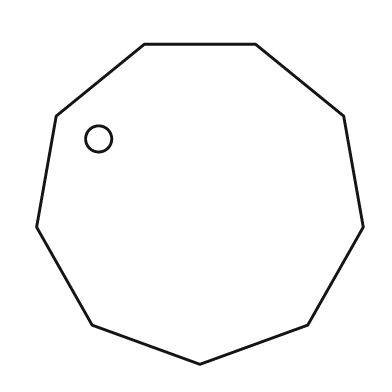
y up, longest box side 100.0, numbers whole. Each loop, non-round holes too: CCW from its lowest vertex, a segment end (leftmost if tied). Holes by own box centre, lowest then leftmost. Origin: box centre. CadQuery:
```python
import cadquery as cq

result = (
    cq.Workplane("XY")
    .moveTo(0.0, -49.0)
    .lineTo(33.0, -37.0)
    .lineTo(50.0, -7.0)
    .lineTo(44.0, 27.0)
    .lineTo(17.0, 49.0)
    .lineTo(-17.0, 49.0)
    .lineTo(-44.0, 27.0)
    .lineTo(-50.0, -7.0)
    .lineTo(-33.0, -37.0)
    .close()
    .moveTo(-31.0, 20.0)
    .circle(4.0)
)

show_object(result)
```